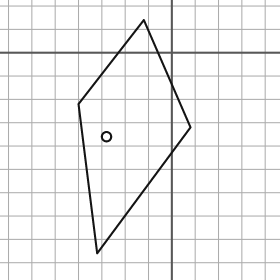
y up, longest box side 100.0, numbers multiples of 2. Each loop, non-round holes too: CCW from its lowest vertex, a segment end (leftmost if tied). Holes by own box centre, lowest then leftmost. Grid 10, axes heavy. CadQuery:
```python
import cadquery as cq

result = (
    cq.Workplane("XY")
    .moveTo(-32.0, -86.0)
    .lineTo(8.0, -32.0)
    .lineTo(-12.0, 14.0)
    .lineTo(-40.0, -22.0)
    .close()
    .moveTo(-28.0, -36.0)
    .circle(2.0)
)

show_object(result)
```